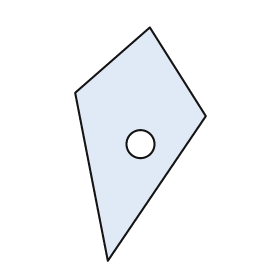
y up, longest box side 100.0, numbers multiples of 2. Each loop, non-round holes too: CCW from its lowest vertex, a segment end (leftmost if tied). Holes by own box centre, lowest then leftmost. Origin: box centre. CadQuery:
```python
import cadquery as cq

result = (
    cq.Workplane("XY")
    .moveTo(-14.0, -50.0)
    .lineTo(28.0, 12.0)
    .lineTo(4.0, 50.0)
    .lineTo(-28.0, 22.0)
    .close()
    .moveTo(0.0, 0.0)
    .circle(6.0)
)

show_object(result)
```